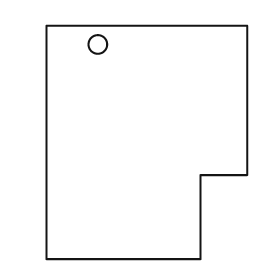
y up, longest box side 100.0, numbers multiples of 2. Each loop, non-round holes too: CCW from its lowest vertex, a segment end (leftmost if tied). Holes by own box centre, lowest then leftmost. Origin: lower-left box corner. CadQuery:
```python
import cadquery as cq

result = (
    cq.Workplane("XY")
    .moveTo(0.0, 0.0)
    .lineTo(66.0, 0.0)
    .lineTo(66.0, 36.0)
    .lineTo(86.0, 36.0)
    .lineTo(86.0, 100.0)
    .lineTo(0.0, 100.0)
    .close()
    .moveTo(22.0, 92.0)
    .circle(4.0)
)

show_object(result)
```